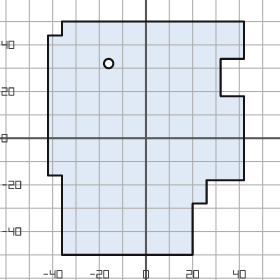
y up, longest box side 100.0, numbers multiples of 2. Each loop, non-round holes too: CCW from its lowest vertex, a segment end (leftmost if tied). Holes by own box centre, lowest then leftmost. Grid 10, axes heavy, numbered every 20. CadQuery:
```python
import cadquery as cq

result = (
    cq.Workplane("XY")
    .moveTo(-36.0, -50.0)
    .lineTo(20.0, -50.0)
    .lineTo(20.0, -28.0)
    .lineTo(26.0, -28.0)
    .lineTo(26.0, -18.0)
    .lineTo(42.0, -18.0)
    .lineTo(42.0, 18.0)
    .lineTo(32.0, 18.0)
    .lineTo(32.0, 34.0)
    .lineTo(42.0, 34.0)
    .lineTo(42.0, 50.0)
    .lineTo(-36.0, 50.0)
    .lineTo(-36.0, 44.0)
    .lineTo(-42.0, 44.0)
    .lineTo(-42.0, -16.0)
    .lineTo(-36.0, -16.0)
    .close()
    .moveTo(-16.0, 32.0)
    .circle(2.0)
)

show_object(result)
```